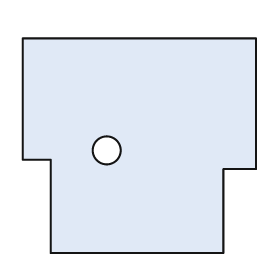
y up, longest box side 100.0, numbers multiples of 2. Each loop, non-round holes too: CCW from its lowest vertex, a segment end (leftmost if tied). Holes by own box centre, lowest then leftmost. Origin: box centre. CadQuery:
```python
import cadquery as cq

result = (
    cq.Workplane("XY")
    .moveTo(-38.0, -46.0)
    .lineTo(36.0, -46.0)
    .lineTo(36.0, -10.0)
    .lineTo(50.0, -10.0)
    .lineTo(50.0, 46.0)
    .lineTo(-50.0, 46.0)
    .lineTo(-50.0, -6.0)
    .lineTo(-38.0, -6.0)
    .close()
    .moveTo(-14.0, -2.0)
    .circle(6.0)
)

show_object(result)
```